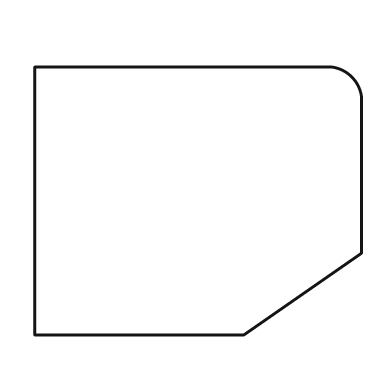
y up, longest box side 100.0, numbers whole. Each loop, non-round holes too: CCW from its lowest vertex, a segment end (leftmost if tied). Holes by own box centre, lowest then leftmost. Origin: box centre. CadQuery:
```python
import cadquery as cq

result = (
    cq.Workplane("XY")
    .moveTo(-50.0, -41.0)
    .lineTo(14.0, -41.0)
    .lineTo(50.0, -16.0)
    .lineTo(50.0, 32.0)
    .threePointArc((47.0, 38.0), (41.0, 41.0))
    .lineTo(-50.0, 41.0)
    .close()
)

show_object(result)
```